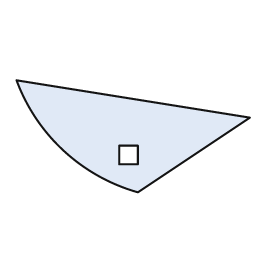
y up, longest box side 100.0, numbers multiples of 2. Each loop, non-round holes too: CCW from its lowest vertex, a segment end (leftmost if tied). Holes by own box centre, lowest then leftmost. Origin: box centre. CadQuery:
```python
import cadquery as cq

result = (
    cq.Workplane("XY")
    .moveTo(2.0, -24.0)
    .lineTo(50.0, 8.0)
    .lineTo(-50.0, 24.0)
    .threePointArc((-30.0, -6.0), (2.0, -24.0))
    .close()
    .moveTo(-6.0, -12.0)
    .lineTo(2.0, -12.0)
    .lineTo(2.0, -4.0)
    .lineTo(-6.0, -4.0)
    .close()
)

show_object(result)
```